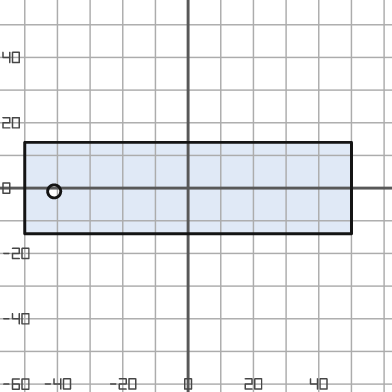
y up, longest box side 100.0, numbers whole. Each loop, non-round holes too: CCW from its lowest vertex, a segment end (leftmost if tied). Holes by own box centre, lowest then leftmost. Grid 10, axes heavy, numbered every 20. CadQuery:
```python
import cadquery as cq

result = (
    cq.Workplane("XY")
    .moveTo(-50.0, -14.0)
    .lineTo(50.0, -14.0)
    .lineTo(50.0, 14.0)
    .lineTo(-50.0, 14.0)
    .close()
    .moveTo(-41.0, -1.0)
    .circle(2.0)
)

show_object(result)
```